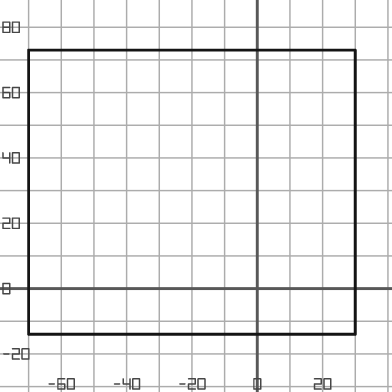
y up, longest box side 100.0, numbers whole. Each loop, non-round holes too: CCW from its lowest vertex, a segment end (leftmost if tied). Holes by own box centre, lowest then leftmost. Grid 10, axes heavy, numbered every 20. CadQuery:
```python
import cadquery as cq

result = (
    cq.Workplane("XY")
    .moveTo(-70.0, -14.0)
    .lineTo(30.0, -14.0)
    .lineTo(30.0, 73.0)
    .lineTo(-70.0, 73.0)
    .close()
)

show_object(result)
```